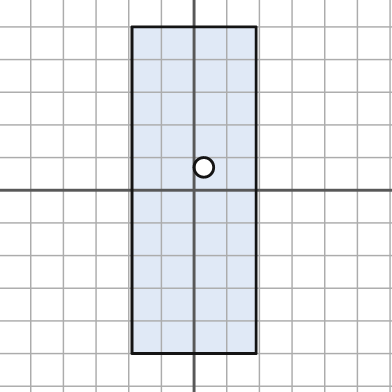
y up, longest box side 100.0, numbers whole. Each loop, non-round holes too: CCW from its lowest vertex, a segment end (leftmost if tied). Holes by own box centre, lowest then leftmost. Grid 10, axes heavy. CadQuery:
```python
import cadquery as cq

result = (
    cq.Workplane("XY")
    .moveTo(-19.0, -50.0)
    .lineTo(19.0, -50.0)
    .lineTo(19.0, 50.0)
    .lineTo(-19.0, 50.0)
    .close()
    .moveTo(3.0, 7.0)
    .circle(3.0)
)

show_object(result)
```